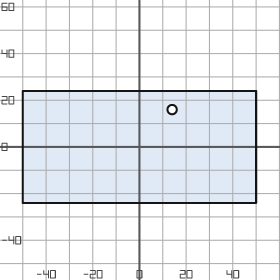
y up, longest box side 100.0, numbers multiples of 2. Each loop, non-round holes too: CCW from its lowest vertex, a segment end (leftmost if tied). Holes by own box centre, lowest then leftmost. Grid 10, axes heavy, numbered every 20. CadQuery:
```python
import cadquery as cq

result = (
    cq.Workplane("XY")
    .moveTo(-50.0, -24.0)
    .lineTo(50.0, -24.0)
    .lineTo(50.0, 24.0)
    .lineTo(-50.0, 24.0)
    .close()
    .moveTo(14.0, 16.0)
    .circle(2.0)
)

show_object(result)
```